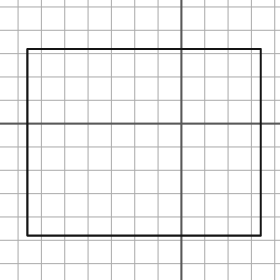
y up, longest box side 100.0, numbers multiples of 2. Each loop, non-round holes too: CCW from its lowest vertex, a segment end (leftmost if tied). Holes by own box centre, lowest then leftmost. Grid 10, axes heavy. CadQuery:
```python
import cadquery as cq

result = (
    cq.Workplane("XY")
    .moveTo(-66.0, -48.0)
    .lineTo(34.0, -48.0)
    .lineTo(34.0, 32.0)
    .lineTo(-66.0, 32.0)
    .close()
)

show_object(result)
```